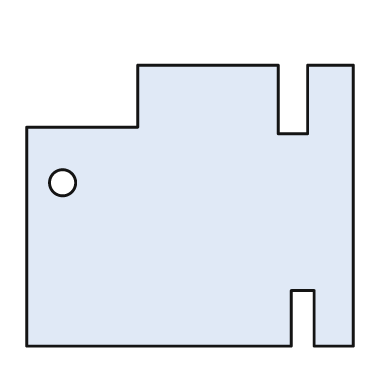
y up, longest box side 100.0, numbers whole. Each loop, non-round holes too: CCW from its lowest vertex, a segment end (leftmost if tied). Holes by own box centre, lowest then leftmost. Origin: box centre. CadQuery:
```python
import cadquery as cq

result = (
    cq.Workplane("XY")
    .moveTo(-50.0, -43.0)
    .lineTo(31.0, -43.0)
    .lineTo(31.0, -26.0)
    .lineTo(38.0, -26.0)
    .lineTo(38.0, -43.0)
    .lineTo(50.0, -43.0)
    .lineTo(50.0, 43.0)
    .lineTo(36.0, 43.0)
    .lineTo(36.0, 22.0)
    .lineTo(27.0, 22.0)
    .lineTo(27.0, 43.0)
    .lineTo(-16.0, 43.0)
    .lineTo(-16.0, 24.0)
    .lineTo(-50.0, 24.0)
    .close()
    .moveTo(-39.0, 7.0)
    .circle(4.0)
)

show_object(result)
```